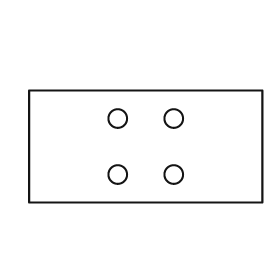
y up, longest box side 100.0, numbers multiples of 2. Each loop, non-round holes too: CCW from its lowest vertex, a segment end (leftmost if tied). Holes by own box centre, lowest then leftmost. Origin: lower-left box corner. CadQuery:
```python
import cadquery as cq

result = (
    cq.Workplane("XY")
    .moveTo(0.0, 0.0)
    .lineTo(100.0, 0.0)
    .lineTo(100.0, 48.0)
    .lineTo(0.0, 48.0)
    .close()
    .moveTo(38.0, 12.0)
    .circle(4.0)
    .moveTo(62.0, 12.0)
    .circle(4.0)
    .moveTo(38.0, 36.0)
    .circle(4.0)
    .moveTo(62.0, 36.0)
    .circle(4.0)
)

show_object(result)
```